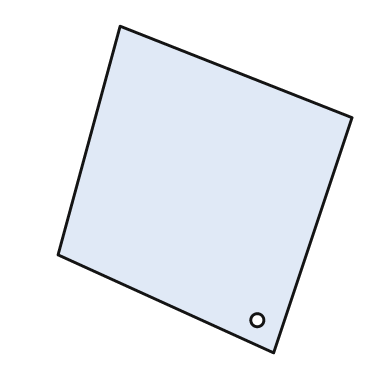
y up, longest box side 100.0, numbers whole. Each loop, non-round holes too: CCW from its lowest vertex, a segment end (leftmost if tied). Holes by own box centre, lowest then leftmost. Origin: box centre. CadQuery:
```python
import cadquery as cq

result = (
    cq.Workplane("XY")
    .moveTo(21.0, -50.0)
    .lineTo(45.0, 22.0)
    .lineTo(-26.0, 50.0)
    .lineTo(-45.0, -20.0)
    .close()
    .moveTo(16.0, -40.0)
    .circle(2.0)
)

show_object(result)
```